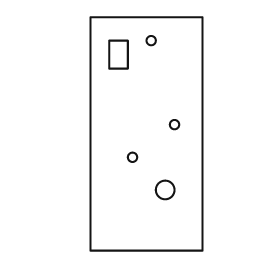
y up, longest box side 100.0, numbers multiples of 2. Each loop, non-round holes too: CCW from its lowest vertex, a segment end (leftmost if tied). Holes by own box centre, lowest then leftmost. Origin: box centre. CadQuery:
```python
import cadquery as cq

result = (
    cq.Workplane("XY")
    .moveTo(-24.0, -50.0)
    .lineTo(24.0, -50.0)
    .lineTo(24.0, 50.0)
    .lineTo(-24.0, 50.0)
    .close()
    .moveTo(8.0, -24.0)
    .circle(4.0)
    .moveTo(-6.0, -10.0)
    .circle(2.0)
    .moveTo(12.0, 4.0)
    .circle(2.0)
    .moveTo(-16.0, 28.0)
    .lineTo(-8.0, 28.0)
    .lineTo(-8.0, 40.0)
    .lineTo(-16.0, 40.0)
    .close()
    .moveTo(2.0, 40.0)
    .circle(2.0)
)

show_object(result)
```